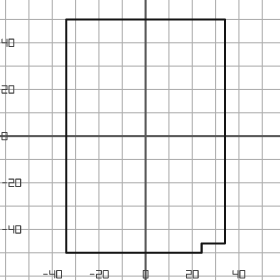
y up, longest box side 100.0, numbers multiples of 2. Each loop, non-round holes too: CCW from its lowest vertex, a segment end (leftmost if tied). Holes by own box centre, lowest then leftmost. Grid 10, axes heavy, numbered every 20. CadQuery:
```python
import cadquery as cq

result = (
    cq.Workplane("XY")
    .moveTo(-34.0, -50.0)
    .lineTo(24.0, -50.0)
    .lineTo(24.0, -46.0)
    .lineTo(34.0, -46.0)
    .lineTo(34.0, 50.0)
    .lineTo(-34.0, 50.0)
    .close()
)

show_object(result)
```